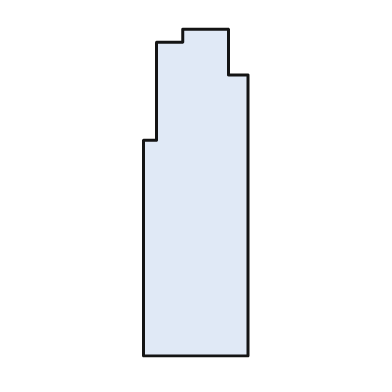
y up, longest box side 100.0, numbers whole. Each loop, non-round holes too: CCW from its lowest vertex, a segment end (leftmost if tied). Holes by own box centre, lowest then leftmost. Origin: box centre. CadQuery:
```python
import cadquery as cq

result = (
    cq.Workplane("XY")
    .moveTo(-16.0, -50.0)
    .lineTo(16.0, -50.0)
    .lineTo(16.0, 36.0)
    .lineTo(10.0, 36.0)
    .lineTo(10.0, 50.0)
    .lineTo(-4.0, 50.0)
    .lineTo(-4.0, 46.0)
    .lineTo(-12.0, 46.0)
    .lineTo(-12.0, 16.0)
    .lineTo(-16.0, 16.0)
    .close()
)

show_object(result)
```